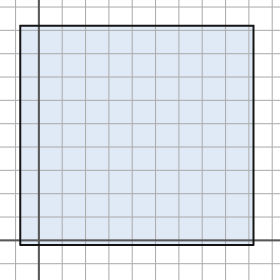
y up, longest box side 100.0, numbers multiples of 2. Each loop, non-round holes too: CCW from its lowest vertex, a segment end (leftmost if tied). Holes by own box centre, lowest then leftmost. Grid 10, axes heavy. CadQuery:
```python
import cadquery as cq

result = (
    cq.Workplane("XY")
    .moveTo(-8.0, -2.0)
    .lineTo(92.0, -2.0)
    .lineTo(92.0, 92.0)
    .lineTo(-8.0, 92.0)
    .close()
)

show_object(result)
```